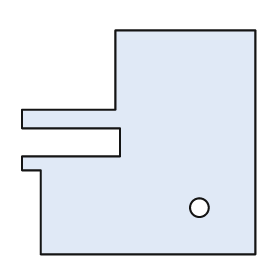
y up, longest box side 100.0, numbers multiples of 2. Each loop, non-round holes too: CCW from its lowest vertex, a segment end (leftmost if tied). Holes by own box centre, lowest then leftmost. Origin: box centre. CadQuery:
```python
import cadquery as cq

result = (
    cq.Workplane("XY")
    .moveTo(-42.0, -48.0)
    .lineTo(50.0, -48.0)
    .lineTo(50.0, 48.0)
    .lineTo(-10.0, 48.0)
    .lineTo(-10.0, 14.0)
    .lineTo(-50.0, 14.0)
    .lineTo(-50.0, 6.0)
    .lineTo(-8.0, 6.0)
    .lineTo(-8.0, -6.0)
    .lineTo(-50.0, -6.0)
    .lineTo(-50.0, -12.0)
    .lineTo(-42.0, -12.0)
    .close()
    .moveTo(26.0, -28.0)
    .circle(4.0)
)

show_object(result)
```